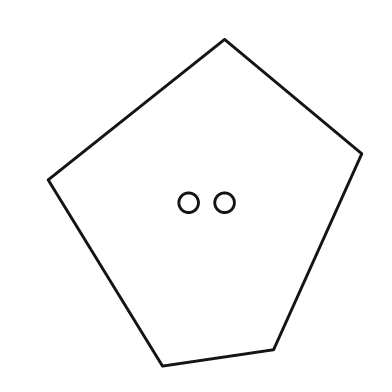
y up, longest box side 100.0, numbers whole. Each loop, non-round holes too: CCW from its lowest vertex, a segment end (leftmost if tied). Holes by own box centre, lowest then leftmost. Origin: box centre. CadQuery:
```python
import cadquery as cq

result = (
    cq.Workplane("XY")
    .moveTo(-13.0, -50.0)
    .lineTo(21.0, -45.0)
    .lineTo(48.0, 15.0)
    .lineTo(6.0, 50.0)
    .lineTo(-48.0, 7.0)
    .close()
    .moveTo(-5.0, 0.0)
    .circle(3.0)
    .moveTo(6.0, 0.0)
    .circle(3.0)
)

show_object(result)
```